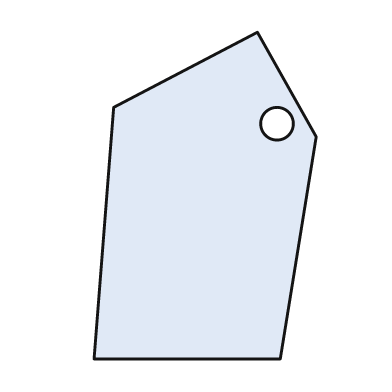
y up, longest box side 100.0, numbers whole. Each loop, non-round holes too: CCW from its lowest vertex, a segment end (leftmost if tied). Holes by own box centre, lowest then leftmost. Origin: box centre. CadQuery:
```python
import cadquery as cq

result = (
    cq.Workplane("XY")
    .moveTo(-34.0, -50.0)
    .lineTo(23.0, -50.0)
    .lineTo(34.0, 18.0)
    .lineTo(16.0, 50.0)
    .lineTo(-28.0, 27.0)
    .close()
    .moveTo(22.0, 22.0)
    .circle(5.0)
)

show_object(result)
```